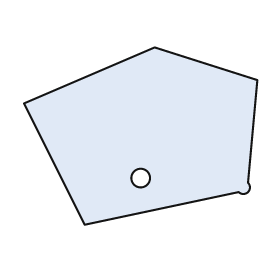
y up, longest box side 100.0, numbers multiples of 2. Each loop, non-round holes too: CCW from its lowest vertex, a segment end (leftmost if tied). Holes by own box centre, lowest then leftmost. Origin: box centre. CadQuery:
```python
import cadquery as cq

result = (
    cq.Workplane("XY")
    .moveTo(-24.0, -38.0)
    .lineTo(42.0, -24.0)
    .threePointArc((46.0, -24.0), (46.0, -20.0))
    .lineTo(50.0, 24.0)
    .lineTo(6.0, 38.0)
    .lineTo(-50.0, 14.0)
    .close()
    .moveTo(0.0, -18.0)
    .circle(4.0)
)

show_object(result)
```